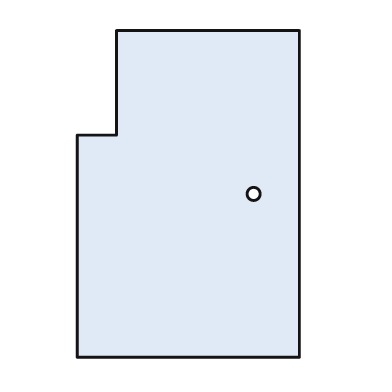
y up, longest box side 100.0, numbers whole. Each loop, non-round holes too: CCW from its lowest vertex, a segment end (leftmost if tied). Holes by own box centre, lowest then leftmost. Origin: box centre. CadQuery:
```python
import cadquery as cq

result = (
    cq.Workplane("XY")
    .moveTo(-34.0, -50.0)
    .lineTo(34.0, -50.0)
    .lineTo(34.0, 50.0)
    .lineTo(-22.0, 50.0)
    .lineTo(-22.0, 18.0)
    .lineTo(-34.0, 18.0)
    .close()
    .moveTo(20.0, 0.0)
    .circle(2.0)
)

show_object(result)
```